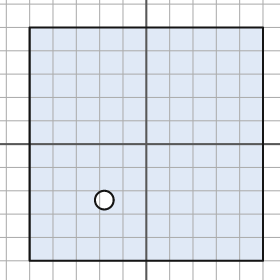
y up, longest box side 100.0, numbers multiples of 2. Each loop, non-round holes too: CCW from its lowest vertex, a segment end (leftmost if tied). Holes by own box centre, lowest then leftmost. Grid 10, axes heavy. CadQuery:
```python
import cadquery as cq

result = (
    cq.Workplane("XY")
    .moveTo(-50.0, -50.0)
    .lineTo(50.0, -50.0)
    .lineTo(50.0, 50.0)
    .lineTo(-50.0, 50.0)
    .close()
    .moveTo(-18.0, -24.0)
    .circle(4.0)
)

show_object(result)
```